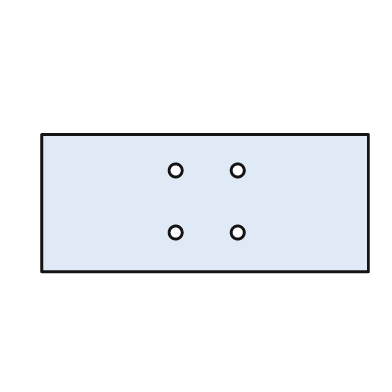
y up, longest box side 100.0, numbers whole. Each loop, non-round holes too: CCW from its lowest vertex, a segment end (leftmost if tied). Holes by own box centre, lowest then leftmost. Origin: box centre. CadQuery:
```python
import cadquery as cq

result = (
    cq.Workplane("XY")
    .moveTo(-50.0, -21.0)
    .lineTo(50.0, -21.0)
    .lineTo(50.0, 21.0)
    .lineTo(-50.0, 21.0)
    .close()
    .moveTo(-9.0, -9.0)
    .circle(2.0)
    .moveTo(10.0, -9.0)
    .circle(2.0)
    .moveTo(-9.0, 10.0)
    .circle(2.0)
    .moveTo(10.0, 10.0)
    .circle(2.0)
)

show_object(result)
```